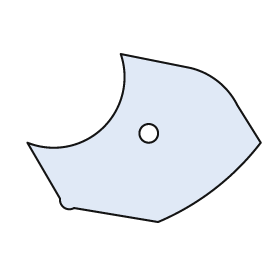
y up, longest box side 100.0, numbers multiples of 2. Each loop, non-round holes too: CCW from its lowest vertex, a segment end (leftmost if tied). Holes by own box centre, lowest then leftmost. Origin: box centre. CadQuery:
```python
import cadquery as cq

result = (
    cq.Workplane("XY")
    .moveTo(6.0, -36.0)
    .threePointArc((30.0, -22.0), (50.0, -2.0))
    .lineTo(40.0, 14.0)
    .threePointArc((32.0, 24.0), (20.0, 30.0))
    .lineTo(-10.0, 36.0)
    .threePointArc((-18.0, 4.0), (-50.0, -2.0))
    .lineTo(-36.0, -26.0)
    .threePointArc((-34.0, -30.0), (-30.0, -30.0))
    .close()
    .moveTo(2.0, 2.0)
    .circle(4.0)
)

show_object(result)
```